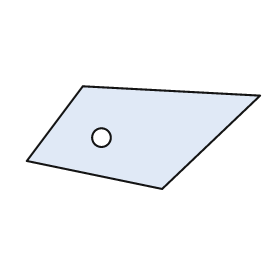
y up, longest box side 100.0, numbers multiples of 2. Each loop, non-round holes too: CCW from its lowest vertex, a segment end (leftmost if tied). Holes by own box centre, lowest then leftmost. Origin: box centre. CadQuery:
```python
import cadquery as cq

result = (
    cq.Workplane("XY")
    .moveTo(8.0, -22.0)
    .lineTo(50.0, 18.0)
    .lineTo(-26.0, 22.0)
    .lineTo(-50.0, -10.0)
    .close()
    .moveTo(-18.0, 0.0)
    .circle(4.0)
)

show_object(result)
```